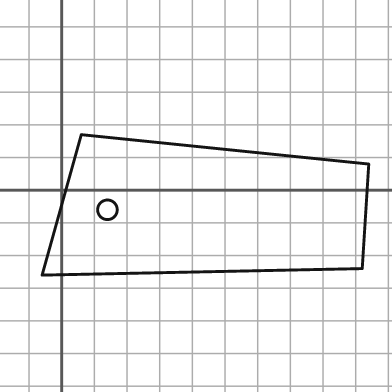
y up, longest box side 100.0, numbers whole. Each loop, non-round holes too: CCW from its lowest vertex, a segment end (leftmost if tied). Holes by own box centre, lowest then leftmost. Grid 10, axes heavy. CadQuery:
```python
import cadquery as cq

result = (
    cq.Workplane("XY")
    .moveTo(-6.0, -26.0)
    .lineTo(92.0, -24.0)
    .lineTo(94.0, 8.0)
    .lineTo(6.0, 17.0)
    .close()
    .moveTo(14.0, -6.0)
    .circle(3.0)
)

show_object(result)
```